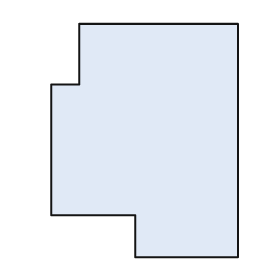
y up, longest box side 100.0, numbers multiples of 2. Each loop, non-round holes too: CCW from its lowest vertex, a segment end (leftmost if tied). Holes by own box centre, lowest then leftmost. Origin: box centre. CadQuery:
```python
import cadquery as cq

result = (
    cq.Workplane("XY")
    .moveTo(-4.0, -50.0)
    .lineTo(40.0, -50.0)
    .lineTo(40.0, 50.0)
    .lineTo(-28.0, 50.0)
    .lineTo(-28.0, 24.0)
    .lineTo(-40.0, 24.0)
    .lineTo(-40.0, -32.0)
    .lineTo(-4.0, -32.0)
    .close()
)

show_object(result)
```